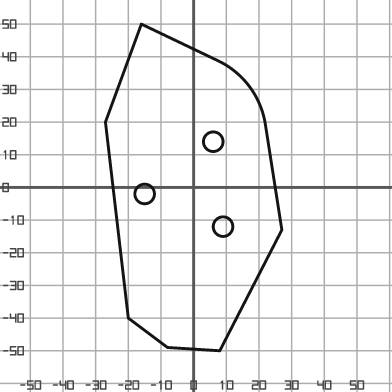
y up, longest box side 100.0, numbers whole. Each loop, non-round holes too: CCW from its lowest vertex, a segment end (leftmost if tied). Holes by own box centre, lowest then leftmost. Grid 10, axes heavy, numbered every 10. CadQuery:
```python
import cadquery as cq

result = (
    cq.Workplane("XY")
    .moveTo(8.0, -50.0)
    .lineTo(27.0, -13.0)
    .lineTo(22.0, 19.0)
    .threePointArc((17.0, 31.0), (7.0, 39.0))
    .lineTo(-16.0, 50.0)
    .lineTo(-27.0, 20.0)
    .lineTo(-20.0, -40.0)
    .lineTo(-8.0, -49.0)
    .close()
    .moveTo(9.0, -12.0)
    .circle(3.0)
    .moveTo(-15.0, -2.0)
    .circle(3.0)
    .moveTo(6.0, 14.0)
    .circle(3.0)
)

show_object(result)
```